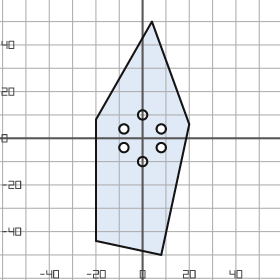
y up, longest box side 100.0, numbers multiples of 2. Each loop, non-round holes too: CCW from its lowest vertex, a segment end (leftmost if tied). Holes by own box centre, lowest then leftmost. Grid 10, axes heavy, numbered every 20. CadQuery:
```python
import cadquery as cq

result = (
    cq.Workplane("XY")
    .moveTo(8.0, -50.0)
    .lineTo(20.0, 6.0)
    .lineTo(4.0, 50.0)
    .lineTo(-20.0, 8.0)
    .lineTo(-20.0, -44.0)
    .close()
    .moveTo(0.0, -10.0)
    .circle(2.0)
    .moveTo(-8.0, -4.0)
    .circle(2.0)
    .moveTo(8.0, -4.0)
    .circle(2.0)
    .moveTo(-8.0, 4.0)
    .circle(2.0)
    .moveTo(8.0, 4.0)
    .circle(2.0)
    .moveTo(0.0, 10.0)
    .circle(2.0)
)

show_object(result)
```